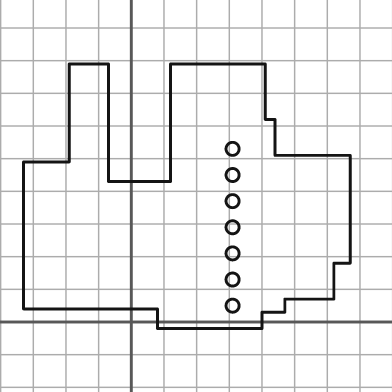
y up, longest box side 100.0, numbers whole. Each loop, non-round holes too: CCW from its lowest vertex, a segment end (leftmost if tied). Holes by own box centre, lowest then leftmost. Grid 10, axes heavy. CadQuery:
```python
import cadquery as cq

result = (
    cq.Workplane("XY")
    .moveTo(8.0, -2.0)
    .lineTo(40.0, -2.0)
    .lineTo(40.0, 3.0)
    .lineTo(47.0, 3.0)
    .lineTo(47.0, 7.0)
    .lineTo(62.0, 7.0)
    .lineTo(62.0, 18.0)
    .lineTo(67.0, 18.0)
    .lineTo(67.0, 51.0)
    .lineTo(44.0, 51.0)
    .lineTo(44.0, 62.0)
    .lineTo(41.0, 62.0)
    .lineTo(41.0, 79.0)
    .lineTo(12.0, 79.0)
    .lineTo(12.0, 43.0)
    .lineTo(-7.0, 43.0)
    .lineTo(-7.0, 79.0)
    .lineTo(-19.0, 79.0)
    .lineTo(-19.0, 49.0)
    .lineTo(-33.0, 49.0)
    .lineTo(-33.0, 4.0)
    .lineTo(8.0, 4.0)
    .close()
    .moveTo(31.0, 5.0)
    .circle(2.0)
    .moveTo(31.0, 13.0)
    .circle(2.0)
    .moveTo(31.0, 21.0)
    .circle(2.0)
    .moveTo(31.0, 29.0)
    .circle(2.0)
    .moveTo(31.0, 37.0)
    .circle(2.0)
    .moveTo(31.0, 45.0)
    .circle(2.0)
    .moveTo(31.0, 53.0)
    .circle(2.0)
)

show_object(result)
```